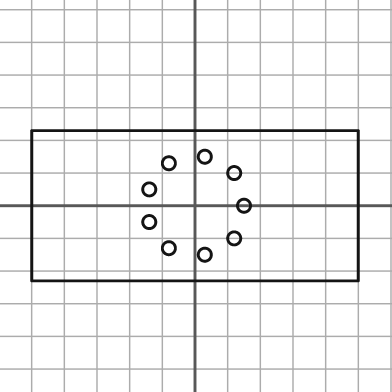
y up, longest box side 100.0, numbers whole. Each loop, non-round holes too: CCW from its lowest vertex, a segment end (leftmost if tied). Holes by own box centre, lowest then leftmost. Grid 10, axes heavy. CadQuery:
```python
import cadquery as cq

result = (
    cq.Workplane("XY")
    .moveTo(-50.0, -23.0)
    .lineTo(50.0, -23.0)
    .lineTo(50.0, 23.0)
    .lineTo(-50.0, 23.0)
    .close()
    .moveTo(3.0, -15.0)
    .circle(2.0)
    .moveTo(-8.0, -13.0)
    .circle(2.0)
    .moveTo(12.0, -10.0)
    .circle(2.0)
    .moveTo(-14.0, -5.0)
    .circle(2.0)
    .moveTo(15.0, 0.0)
    .circle(2.0)
    .moveTo(-14.0, 5.0)
    .circle(2.0)
    .moveTo(12.0, 10.0)
    .circle(2.0)
    .moveTo(-8.0, 13.0)
    .circle(2.0)
    .moveTo(3.0, 15.0)
    .circle(2.0)
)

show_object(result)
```